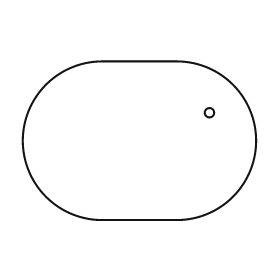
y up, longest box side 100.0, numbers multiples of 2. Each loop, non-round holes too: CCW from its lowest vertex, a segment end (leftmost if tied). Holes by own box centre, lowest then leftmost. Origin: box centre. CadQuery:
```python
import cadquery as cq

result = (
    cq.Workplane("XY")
    .moveTo(-16.0, -34.0)
    .lineTo(16.0, -34.0)
    .threePointArc((50.0, 0.0), (16.0, 34.0))
    .lineTo(-16.0, 34.0)
    .threePointArc((-50.0, 0.0), (-16.0, -34.0))
    .close()
    .moveTo(30.0, 12.0)
    .circle(2.0)
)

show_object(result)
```